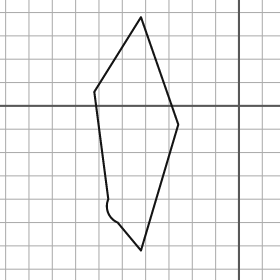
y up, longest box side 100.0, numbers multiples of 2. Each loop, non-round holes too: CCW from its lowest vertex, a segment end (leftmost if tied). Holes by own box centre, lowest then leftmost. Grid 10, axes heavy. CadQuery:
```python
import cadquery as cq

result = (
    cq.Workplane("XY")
    .moveTo(-42.0, -62.0)
    .lineTo(-26.0, -8.0)
    .lineTo(-42.0, 38.0)
    .lineTo(-62.0, 6.0)
    .lineTo(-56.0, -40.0)
    .threePointArc((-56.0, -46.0), (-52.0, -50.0))
    .close()
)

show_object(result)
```